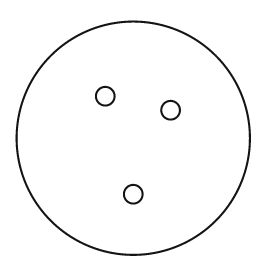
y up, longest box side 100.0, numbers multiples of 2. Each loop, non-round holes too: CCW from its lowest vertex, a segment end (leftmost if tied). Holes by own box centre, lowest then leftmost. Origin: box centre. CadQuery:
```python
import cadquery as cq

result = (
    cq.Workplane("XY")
    .moveTo(0.0, 0.0)
    .circle(50.0)
    .moveTo(0.0, -24.0)
    .circle(4.0)
    .moveTo(16.0, 12.0)
    .circle(4.0)
    .moveTo(-12.0, 18.0)
    .circle(4.0)
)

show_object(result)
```